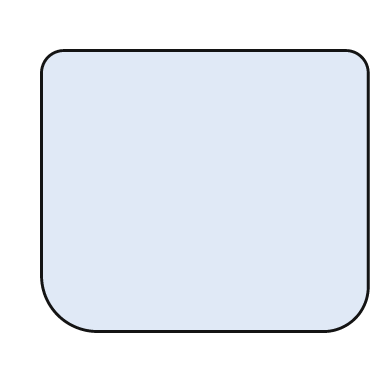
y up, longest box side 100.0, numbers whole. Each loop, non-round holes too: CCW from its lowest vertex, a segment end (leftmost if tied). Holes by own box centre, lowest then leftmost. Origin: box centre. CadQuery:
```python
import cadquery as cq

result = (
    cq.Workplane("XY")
    .moveTo(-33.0, -43.0)
    .lineTo(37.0, -43.0)
    .threePointArc((46.0, -39.0), (50.0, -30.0))
    .lineTo(50.0, 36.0)
    .threePointArc((48.0, 41.0), (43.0, 43.0))
    .lineTo(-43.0, 43.0)
    .threePointArc((-48.0, 41.0), (-50.0, 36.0))
    .lineTo(-50.0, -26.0)
    .threePointArc((-45.0, -38.0), (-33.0, -43.0))
    .close()
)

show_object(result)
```